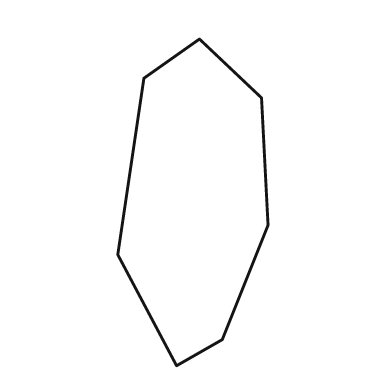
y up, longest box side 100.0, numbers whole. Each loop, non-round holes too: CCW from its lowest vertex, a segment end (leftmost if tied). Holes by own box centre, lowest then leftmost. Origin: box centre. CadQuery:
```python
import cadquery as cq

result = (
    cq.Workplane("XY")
    .moveTo(-5.0, -50.0)
    .lineTo(9.0, -42.0)
    .lineTo(23.0, -7.0)
    .lineTo(21.0, 32.0)
    .lineTo(2.0, 50.0)
    .lineTo(-15.0, 38.0)
    .lineTo(-23.0, -16.0)
    .close()
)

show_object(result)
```